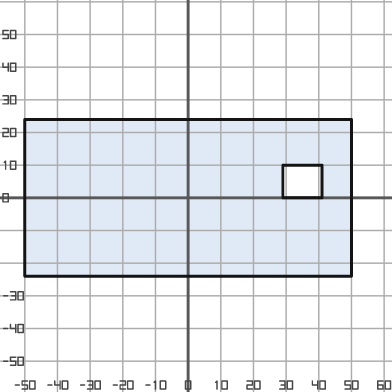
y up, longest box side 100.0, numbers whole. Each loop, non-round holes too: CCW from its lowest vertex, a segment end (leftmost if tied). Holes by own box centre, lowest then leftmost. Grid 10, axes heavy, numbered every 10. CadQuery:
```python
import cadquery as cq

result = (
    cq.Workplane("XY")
    .moveTo(-50.0, -24.0)
    .lineTo(50.0, -24.0)
    .lineTo(50.0, 24.0)
    .lineTo(-50.0, 24.0)
    .close()
    .moveTo(29.0, 0.0)
    .lineTo(41.0, 0.0)
    .lineTo(41.0, 10.0)
    .lineTo(29.0, 10.0)
    .close()
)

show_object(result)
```